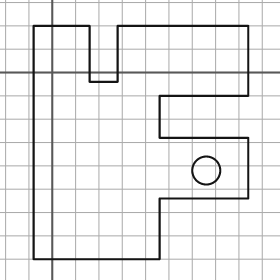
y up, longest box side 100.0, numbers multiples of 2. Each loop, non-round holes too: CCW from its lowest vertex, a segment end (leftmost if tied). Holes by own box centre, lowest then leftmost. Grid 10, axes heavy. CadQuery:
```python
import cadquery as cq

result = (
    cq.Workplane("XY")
    .moveTo(-8.0, -80.0)
    .lineTo(46.0, -80.0)
    .lineTo(46.0, -54.0)
    .lineTo(84.0, -54.0)
    .lineTo(84.0, -28.0)
    .lineTo(46.0, -28.0)
    .lineTo(46.0, -10.0)
    .lineTo(84.0, -10.0)
    .lineTo(84.0, 20.0)
    .lineTo(28.0, 20.0)
    .lineTo(28.0, -4.0)
    .lineTo(16.0, -4.0)
    .lineTo(16.0, 20.0)
    .lineTo(-8.0, 20.0)
    .close()
    .moveTo(66.0, -42.0)
    .circle(6.0)
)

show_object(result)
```